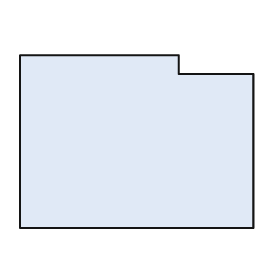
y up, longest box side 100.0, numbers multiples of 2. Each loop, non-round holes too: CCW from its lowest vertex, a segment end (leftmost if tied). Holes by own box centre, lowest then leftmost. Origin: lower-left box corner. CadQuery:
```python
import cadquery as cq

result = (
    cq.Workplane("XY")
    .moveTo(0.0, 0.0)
    .lineTo(100.0, 0.0)
    .lineTo(100.0, 66.0)
    .lineTo(68.0, 66.0)
    .lineTo(68.0, 74.0)
    .lineTo(0.0, 74.0)
    .close()
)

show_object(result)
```